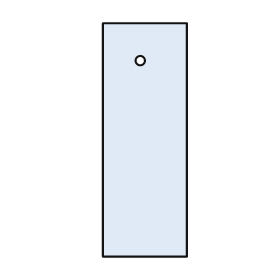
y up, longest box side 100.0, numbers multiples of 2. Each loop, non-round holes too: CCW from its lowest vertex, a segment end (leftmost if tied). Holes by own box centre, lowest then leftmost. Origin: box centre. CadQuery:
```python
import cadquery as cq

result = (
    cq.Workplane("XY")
    .moveTo(-18.0, -50.0)
    .lineTo(18.0, -50.0)
    .lineTo(18.0, 50.0)
    .lineTo(-18.0, 50.0)
    .close()
    .moveTo(-2.0, 34.0)
    .circle(2.0)
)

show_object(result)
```